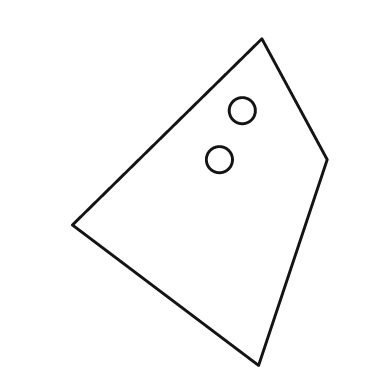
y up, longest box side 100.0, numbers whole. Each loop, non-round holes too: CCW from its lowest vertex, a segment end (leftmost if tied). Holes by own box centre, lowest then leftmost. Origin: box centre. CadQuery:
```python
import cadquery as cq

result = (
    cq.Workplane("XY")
    .moveTo(18.0, -50.0)
    .lineTo(39.0, 13.0)
    .lineTo(19.0, 50.0)
    .lineTo(-39.0, -7.0)
    .close()
    .moveTo(6.0, 13.0)
    .circle(4.0)
    .moveTo(13.0, 28.0)
    .circle(4.0)
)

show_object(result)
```